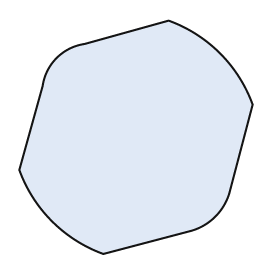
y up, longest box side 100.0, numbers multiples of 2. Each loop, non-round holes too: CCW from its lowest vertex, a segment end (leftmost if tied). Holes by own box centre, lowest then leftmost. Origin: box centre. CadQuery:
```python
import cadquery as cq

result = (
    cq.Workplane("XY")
    .moveTo(-14.0, -50.0)
    .lineTo(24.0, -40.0)
    .threePointArc((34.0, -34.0), (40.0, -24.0))
    .lineTo(50.0, 14.0)
    .threePointArc((36.0, 36.0), (14.0, 50.0))
    .lineTo(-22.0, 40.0)
    .threePointArc((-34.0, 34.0), (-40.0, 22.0))
    .lineTo(-50.0, -14.0)
    .threePointArc((-36.0, -36.0), (-14.0, -50.0))
    .close()
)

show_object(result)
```